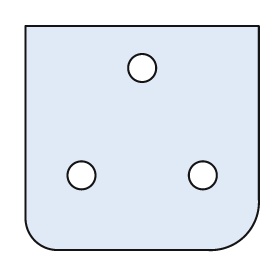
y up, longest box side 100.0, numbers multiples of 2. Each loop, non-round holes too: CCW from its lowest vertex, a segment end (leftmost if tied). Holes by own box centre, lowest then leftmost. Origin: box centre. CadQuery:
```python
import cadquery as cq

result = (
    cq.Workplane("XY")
    .moveTo(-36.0, -48.0)
    .lineTo(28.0, -48.0)
    .threePointArc((44.0, -42.0), (50.0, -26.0))
    .lineTo(50.0, 48.0)
    .lineTo(-50.0, 48.0)
    .lineTo(-50.0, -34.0)
    .threePointArc((-46.0, -44.0), (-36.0, -48.0))
    .close()
    .moveTo(-26.0, -16.0)
    .circle(6.0)
    .moveTo(26.0, -16.0)
    .circle(6.0)
    .moveTo(0.0, 30.0)
    .circle(6.0)
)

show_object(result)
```